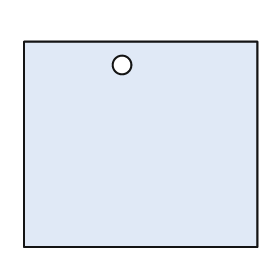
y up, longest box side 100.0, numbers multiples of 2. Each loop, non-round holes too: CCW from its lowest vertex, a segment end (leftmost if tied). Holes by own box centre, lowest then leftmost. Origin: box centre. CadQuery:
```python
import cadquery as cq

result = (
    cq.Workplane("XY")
    .moveTo(-50.0, -44.0)
    .lineTo(50.0, -44.0)
    .lineTo(50.0, 44.0)
    .lineTo(-50.0, 44.0)
    .close()
    .moveTo(-8.0, 34.0)
    .circle(4.0)
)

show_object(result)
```